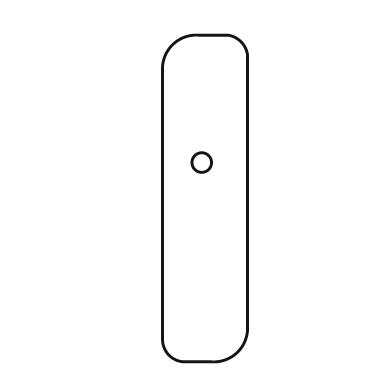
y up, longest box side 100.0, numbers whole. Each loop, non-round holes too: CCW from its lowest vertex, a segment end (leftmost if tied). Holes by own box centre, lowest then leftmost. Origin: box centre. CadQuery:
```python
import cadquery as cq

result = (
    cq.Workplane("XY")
    .moveTo(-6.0, -50.0)
    .lineTo(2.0, -50.0)
    .threePointArc((10.0, -47.0), (13.0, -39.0))
    .lineTo(13.0, 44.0)
    .threePointArc((11.0, 48.0), (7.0, 50.0))
    .lineTo(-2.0, 50.0)
    .threePointArc((-10.0, 47.0), (-13.0, 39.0))
    .lineTo(-13.0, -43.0)
    .threePointArc((-11.0, -48.0), (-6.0, -50.0))
    .close()
    .moveTo(-1.0, 11.0)
    .circle(3.0)
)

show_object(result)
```